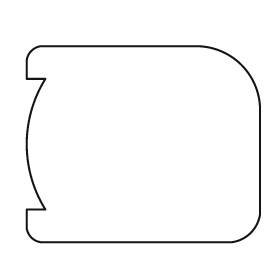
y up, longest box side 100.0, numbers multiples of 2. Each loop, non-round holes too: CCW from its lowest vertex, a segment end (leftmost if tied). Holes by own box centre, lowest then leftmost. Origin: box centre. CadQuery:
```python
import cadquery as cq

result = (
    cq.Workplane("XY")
    .moveTo(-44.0, -42.0)
    .lineTo(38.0, -42.0)
    .threePointArc((46.0, -38.0), (50.0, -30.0))
    .lineTo(50.0, 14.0)
    .threePointArc((42.0, 34.0), (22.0, 42.0))
    .lineTo(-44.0, 42.0)
    .threePointArc((-48.0, 40.0), (-50.0, 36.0))
    .lineTo(-50.0, 28.0)
    .lineTo(-42.0, 28.0)
    .threePointArc((-50.0, 0.0), (-42.0, -28.0))
    .lineTo(-50.0, -28.0)
    .lineTo(-50.0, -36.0)
    .threePointArc((-48.0, -40.0), (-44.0, -42.0))
    .close()
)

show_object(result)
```